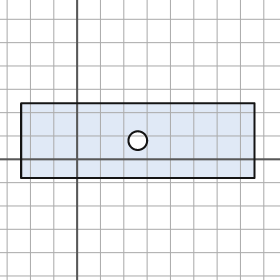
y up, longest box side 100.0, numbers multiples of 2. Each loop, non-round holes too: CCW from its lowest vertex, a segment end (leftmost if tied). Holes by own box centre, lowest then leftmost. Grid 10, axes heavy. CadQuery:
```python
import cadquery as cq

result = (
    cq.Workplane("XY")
    .moveTo(-24.0, -8.0)
    .lineTo(76.0, -8.0)
    .lineTo(76.0, 24.0)
    .lineTo(-24.0, 24.0)
    .close()
    .moveTo(26.0, 8.0)
    .circle(4.0)
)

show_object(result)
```